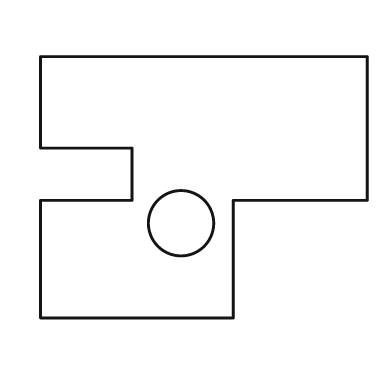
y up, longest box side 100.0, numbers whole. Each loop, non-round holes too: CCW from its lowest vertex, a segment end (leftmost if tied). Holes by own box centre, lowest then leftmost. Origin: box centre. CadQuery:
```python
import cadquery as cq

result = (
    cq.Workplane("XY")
    .moveTo(-50.0, -40.0)
    .lineTo(9.0, -40.0)
    .lineTo(9.0, -4.0)
    .lineTo(50.0, -4.0)
    .lineTo(50.0, 40.0)
    .lineTo(-50.0, 40.0)
    .lineTo(-50.0, 12.0)
    .lineTo(-22.0, 12.0)
    .lineTo(-22.0, -4.0)
    .lineTo(-50.0, -4.0)
    .close()
    .moveTo(-7.0, -11.0)
    .circle(10.0)
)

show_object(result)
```